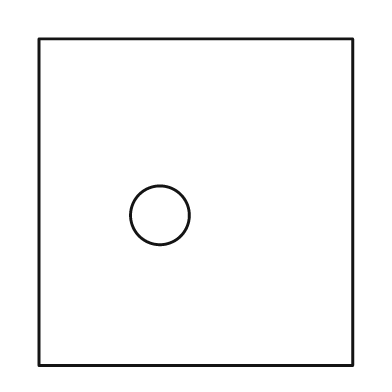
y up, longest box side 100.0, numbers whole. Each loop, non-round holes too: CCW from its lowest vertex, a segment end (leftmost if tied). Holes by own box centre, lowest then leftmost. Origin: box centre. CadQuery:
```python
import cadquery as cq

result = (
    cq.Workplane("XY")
    .moveTo(-48.0, -50.0)
    .lineTo(48.0, -50.0)
    .lineTo(48.0, 50.0)
    .lineTo(-48.0, 50.0)
    .close()
    .moveTo(-11.0, -4.0)
    .circle(9.0)
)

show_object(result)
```